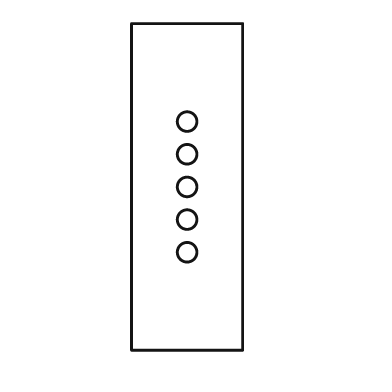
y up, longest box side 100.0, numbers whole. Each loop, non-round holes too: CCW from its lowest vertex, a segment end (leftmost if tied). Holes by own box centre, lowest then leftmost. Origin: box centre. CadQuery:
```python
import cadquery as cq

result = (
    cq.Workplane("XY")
    .moveTo(-17.0, -50.0)
    .lineTo(17.0, -50.0)
    .lineTo(17.0, 50.0)
    .lineTo(-17.0, 50.0)
    .close()
    .moveTo(0.0, -20.0)
    .circle(3.0)
    .moveTo(0.0, -10.0)
    .circle(3.0)
    .moveTo(0.0, 0.0)
    .circle(3.0)
    .moveTo(0.0, 10.0)
    .circle(3.0)
    .moveTo(0.0, 20.0)
    .circle(3.0)
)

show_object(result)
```